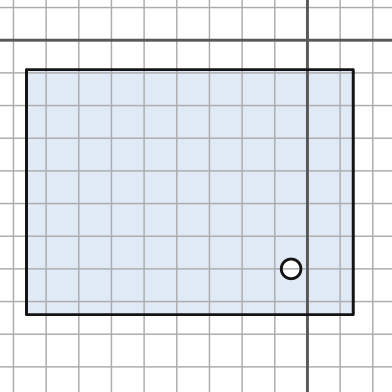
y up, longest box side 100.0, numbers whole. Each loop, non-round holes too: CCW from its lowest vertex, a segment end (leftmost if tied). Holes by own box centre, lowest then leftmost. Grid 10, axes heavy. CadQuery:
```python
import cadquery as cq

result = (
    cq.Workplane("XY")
    .moveTo(-86.0, -84.0)
    .lineTo(14.0, -84.0)
    .lineTo(14.0, -9.0)
    .lineTo(-86.0, -9.0)
    .close()
    .moveTo(-5.0, -70.0)
    .circle(3.0)
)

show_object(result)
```